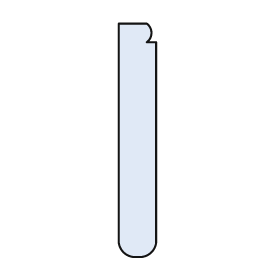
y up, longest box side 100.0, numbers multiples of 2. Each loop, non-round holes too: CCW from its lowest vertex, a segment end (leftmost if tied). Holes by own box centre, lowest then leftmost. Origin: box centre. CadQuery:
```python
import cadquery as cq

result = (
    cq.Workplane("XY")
    .moveTo(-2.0, -50.0)
    .lineTo(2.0, -50.0)
    .threePointArc((6.0, -48.0), (8.0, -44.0))
    .lineTo(8.0, 42.0)
    .lineTo(4.0, 42.0)
    .threePointArc((6.0, 46.0), (4.0, 50.0))
    .lineTo(-8.0, 50.0)
    .lineTo(-8.0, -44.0)
    .threePointArc((-6.0, -48.0), (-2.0, -50.0))
    .close()
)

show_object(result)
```